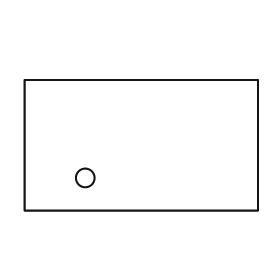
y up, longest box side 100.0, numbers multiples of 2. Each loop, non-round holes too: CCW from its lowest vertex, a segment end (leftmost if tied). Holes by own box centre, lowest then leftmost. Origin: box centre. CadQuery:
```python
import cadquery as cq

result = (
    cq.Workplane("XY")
    .moveTo(-50.0, -28.0)
    .lineTo(50.0, -28.0)
    .lineTo(50.0, 28.0)
    .lineTo(-50.0, 28.0)
    .close()
    .moveTo(-24.0, -14.0)
    .circle(4.0)
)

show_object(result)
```